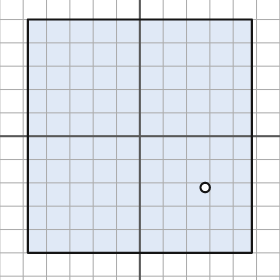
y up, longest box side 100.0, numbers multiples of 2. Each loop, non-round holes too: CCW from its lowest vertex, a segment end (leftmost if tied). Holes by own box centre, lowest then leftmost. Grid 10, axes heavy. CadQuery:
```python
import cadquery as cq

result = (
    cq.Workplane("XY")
    .moveTo(-48.0, -50.0)
    .lineTo(48.0, -50.0)
    .lineTo(48.0, 50.0)
    .lineTo(-48.0, 50.0)
    .close()
    .moveTo(28.0, -22.0)
    .circle(2.0)
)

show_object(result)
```